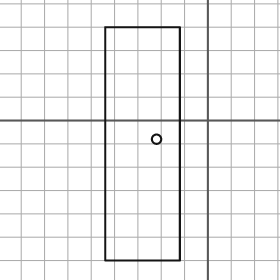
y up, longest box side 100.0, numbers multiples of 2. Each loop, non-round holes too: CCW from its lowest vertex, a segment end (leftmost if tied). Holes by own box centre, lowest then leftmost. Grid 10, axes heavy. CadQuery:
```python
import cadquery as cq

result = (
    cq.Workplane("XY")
    .moveTo(-44.0, -60.0)
    .lineTo(-12.0, -60.0)
    .lineTo(-12.0, 40.0)
    .lineTo(-44.0, 40.0)
    .close()
    .moveTo(-22.0, -8.0)
    .circle(2.0)
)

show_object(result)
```